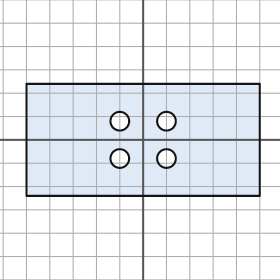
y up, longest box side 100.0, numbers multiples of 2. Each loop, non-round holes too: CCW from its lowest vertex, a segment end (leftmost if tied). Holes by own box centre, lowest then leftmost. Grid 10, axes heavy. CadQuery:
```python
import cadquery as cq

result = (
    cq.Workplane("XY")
    .moveTo(-50.0, -24.0)
    .lineTo(50.0, -24.0)
    .lineTo(50.0, 24.0)
    .lineTo(-50.0, 24.0)
    .close()
    .moveTo(-10.0, -8.0)
    .circle(4.0)
    .moveTo(10.0, -8.0)
    .circle(4.0)
    .moveTo(-10.0, 8.0)
    .circle(4.0)
    .moveTo(10.0, 8.0)
    .circle(4.0)
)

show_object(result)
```